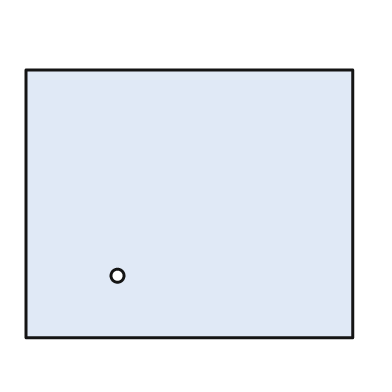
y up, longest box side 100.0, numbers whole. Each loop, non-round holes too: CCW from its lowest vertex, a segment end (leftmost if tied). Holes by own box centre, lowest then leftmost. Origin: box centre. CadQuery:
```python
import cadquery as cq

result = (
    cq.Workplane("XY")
    .moveTo(-50.0, -41.0)
    .lineTo(50.0, -41.0)
    .lineTo(50.0, 41.0)
    .lineTo(-50.0, 41.0)
    .close()
    .moveTo(-22.0, -22.0)
    .circle(2.0)
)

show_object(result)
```